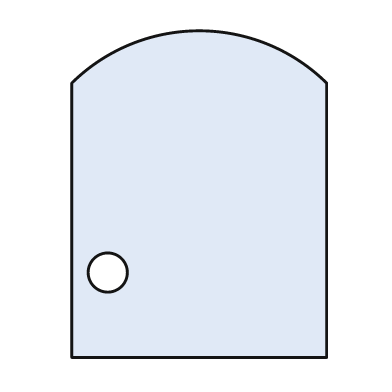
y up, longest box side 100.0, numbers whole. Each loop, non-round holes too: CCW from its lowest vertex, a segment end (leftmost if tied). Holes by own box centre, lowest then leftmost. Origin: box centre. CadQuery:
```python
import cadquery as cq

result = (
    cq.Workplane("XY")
    .moveTo(-39.0, -50.0)
    .lineTo(39.0, -50.0)
    .lineTo(39.0, 34.0)
    .threePointArc((0.0, 50.0), (-39.0, 34.0))
    .close()
    .moveTo(-28.0, -24.0)
    .circle(6.0)
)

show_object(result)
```